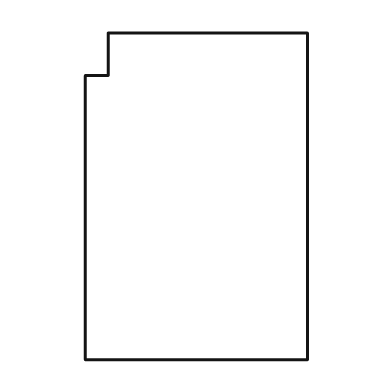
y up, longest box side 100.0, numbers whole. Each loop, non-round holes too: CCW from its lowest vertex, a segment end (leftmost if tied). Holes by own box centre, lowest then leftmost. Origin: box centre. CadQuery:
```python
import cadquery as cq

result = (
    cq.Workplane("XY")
    .moveTo(-34.0, -50.0)
    .lineTo(34.0, -50.0)
    .lineTo(34.0, 50.0)
    .lineTo(-27.0, 50.0)
    .lineTo(-27.0, 37.0)
    .lineTo(-34.0, 37.0)
    .close()
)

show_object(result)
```